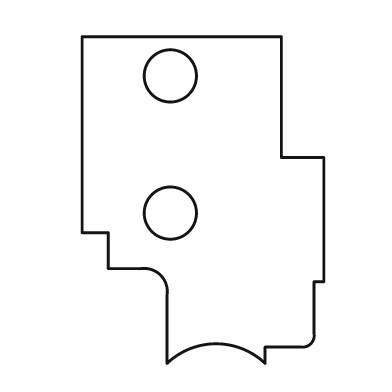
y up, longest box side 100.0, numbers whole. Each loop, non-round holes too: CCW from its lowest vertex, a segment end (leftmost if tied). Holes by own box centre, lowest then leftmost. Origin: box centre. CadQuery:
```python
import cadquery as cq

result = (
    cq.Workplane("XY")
    .moveTo(-11.0, -50.0)
    .threePointArc((4.0, -44.0), (19.0, -50.0))
    .lineTo(19.0, -45.0)
    .lineTo(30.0, -45.0)
    .threePointArc((33.0, -44.0), (34.0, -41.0))
    .lineTo(34.0, -25.0)
    .lineTo(37.0, -25.0)
    .lineTo(37.0, 13.0)
    .lineTo(24.0, 13.0)
    .lineTo(24.0, 50.0)
    .lineTo(-37.0, 50.0)
    .lineTo(-37.0, -10.0)
    .lineTo(-29.0, -10.0)
    .lineTo(-29.0, -21.0)
    .lineTo(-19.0, -21.0)
    .threePointArc((-13.0, -23.0), (-11.0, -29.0))
    .close()
    .moveTo(-10.0, -4.0)
    .circle(8.0)
    .moveTo(-10.0, 38.0)
    .circle(8.0)
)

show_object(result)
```